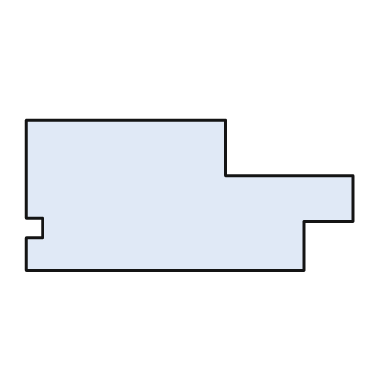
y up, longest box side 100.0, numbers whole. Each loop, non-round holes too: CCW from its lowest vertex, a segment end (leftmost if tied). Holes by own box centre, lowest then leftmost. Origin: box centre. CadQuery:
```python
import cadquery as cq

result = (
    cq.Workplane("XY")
    .moveTo(-50.0, -23.0)
    .lineTo(35.0, -23.0)
    .lineTo(35.0, -8.0)
    .lineTo(50.0, -8.0)
    .lineTo(50.0, 6.0)
    .lineTo(11.0, 6.0)
    .lineTo(11.0, 23.0)
    .lineTo(-50.0, 23.0)
    .lineTo(-50.0, -7.0)
    .lineTo(-45.0, -7.0)
    .lineTo(-45.0, -13.0)
    .lineTo(-50.0, -13.0)
    .close()
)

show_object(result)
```